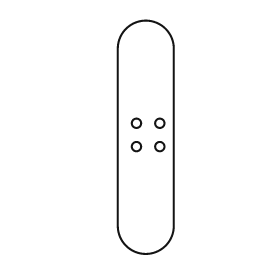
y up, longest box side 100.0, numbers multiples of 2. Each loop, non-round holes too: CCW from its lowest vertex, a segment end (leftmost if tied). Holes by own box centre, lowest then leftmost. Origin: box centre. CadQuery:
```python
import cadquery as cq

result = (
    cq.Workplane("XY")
    .moveTo(-12.0, -38.0)
    .threePointArc((0.0, -50.0), (12.0, -38.0))
    .lineTo(12.0, 38.0)
    .threePointArc((0.0, 50.0), (-12.0, 38.0))
    .close()
    .moveTo(-4.0, -4.0)
    .circle(2.0)
    .moveTo(6.0, -4.0)
    .circle(2.0)
    .moveTo(-4.0, 6.0)
    .circle(2.0)
    .moveTo(6.0, 6.0)
    .circle(2.0)
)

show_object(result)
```